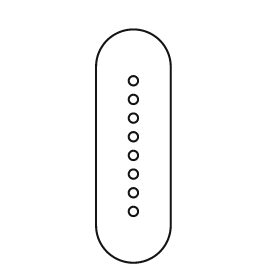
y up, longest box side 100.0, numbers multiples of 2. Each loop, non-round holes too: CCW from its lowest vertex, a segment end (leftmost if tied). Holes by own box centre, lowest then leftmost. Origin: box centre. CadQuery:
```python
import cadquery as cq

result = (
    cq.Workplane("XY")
    .moveTo(-16.0, -34.0)
    .threePointArc((0.0, -50.0), (16.0, -34.0))
    .lineTo(16.0, 34.0)
    .threePointArc((0.0, 50.0), (-16.0, 34.0))
    .close()
    .moveTo(0.0, -28.0)
    .circle(2.0)
    .moveTo(0.0, -20.0)
    .circle(2.0)
    .moveTo(0.0, -12.0)
    .circle(2.0)
    .moveTo(0.0, -4.0)
    .circle(2.0)
    .moveTo(0.0, 4.0)
    .circle(2.0)
    .moveTo(0.0, 12.0)
    .circle(2.0)
    .moveTo(0.0, 20.0)
    .circle(2.0)
    .moveTo(0.0, 28.0)
    .circle(2.0)
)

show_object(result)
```